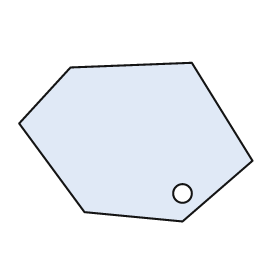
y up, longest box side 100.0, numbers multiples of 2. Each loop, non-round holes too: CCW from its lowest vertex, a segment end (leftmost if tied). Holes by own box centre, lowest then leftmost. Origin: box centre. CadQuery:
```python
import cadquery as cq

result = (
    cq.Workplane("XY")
    .moveTo(20.0, -34.0)
    .lineTo(50.0, -8.0)
    .lineTo(24.0, 34.0)
    .lineTo(-28.0, 32.0)
    .lineTo(-50.0, 8.0)
    .lineTo(-22.0, -30.0)
    .close()
    .moveTo(20.0, -22.0)
    .circle(4.0)
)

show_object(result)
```